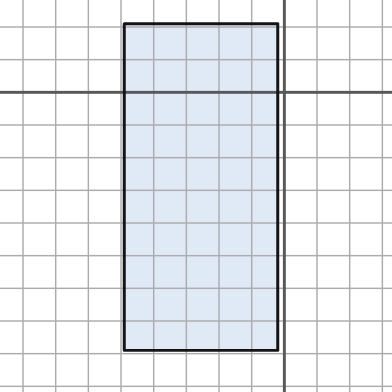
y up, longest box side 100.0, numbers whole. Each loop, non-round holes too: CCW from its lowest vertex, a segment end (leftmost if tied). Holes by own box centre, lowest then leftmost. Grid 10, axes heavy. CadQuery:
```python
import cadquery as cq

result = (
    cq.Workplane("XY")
    .moveTo(-49.0, -79.0)
    .lineTo(-2.0, -79.0)
    .lineTo(-2.0, 21.0)
    .lineTo(-49.0, 21.0)
    .close()
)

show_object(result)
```